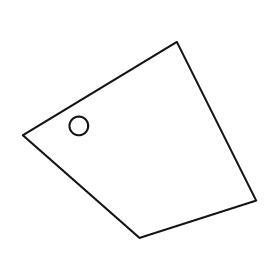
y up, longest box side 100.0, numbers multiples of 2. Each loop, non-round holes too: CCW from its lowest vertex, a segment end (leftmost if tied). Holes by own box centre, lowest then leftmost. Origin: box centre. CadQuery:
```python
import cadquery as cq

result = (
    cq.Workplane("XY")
    .moveTo(0.0, -42.0)
    .lineTo(50.0, -26.0)
    .lineTo(16.0, 42.0)
    .lineTo(-50.0, 2.0)
    .close()
    .moveTo(-26.0, 6.0)
    .circle(4.0)
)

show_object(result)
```